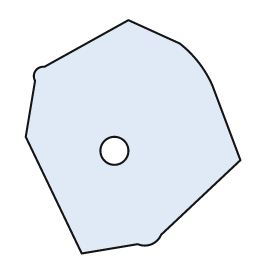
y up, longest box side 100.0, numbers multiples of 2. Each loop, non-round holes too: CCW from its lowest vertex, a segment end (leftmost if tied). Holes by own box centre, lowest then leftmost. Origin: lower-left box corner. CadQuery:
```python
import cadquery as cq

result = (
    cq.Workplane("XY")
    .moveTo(24.0, 0.0)
    .lineTo(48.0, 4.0)
    .threePointArc((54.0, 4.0), (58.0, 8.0))
    .lineTo(92.0, 40.0)
    .lineTo(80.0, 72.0)
    .threePointArc((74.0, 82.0), (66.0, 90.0))
    .lineTo(44.0, 100.0)
    .lineTo(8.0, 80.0)
    .threePointArc((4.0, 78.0), (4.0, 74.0))
    .lineTo(0.0, 50.0)
    .close()
    .moveTo(38.0, 44.0)
    .circle(6.0)
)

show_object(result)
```